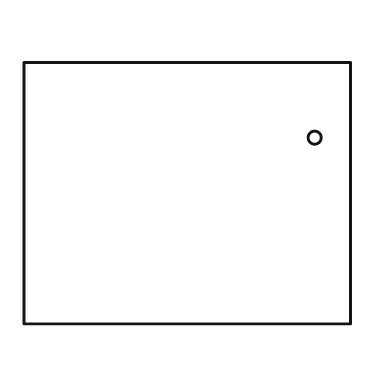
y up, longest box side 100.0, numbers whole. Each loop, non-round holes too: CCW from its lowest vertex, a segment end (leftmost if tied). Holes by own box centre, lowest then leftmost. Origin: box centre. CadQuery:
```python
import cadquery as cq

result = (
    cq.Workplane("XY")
    .moveTo(-50.0, -40.0)
    .lineTo(50.0, -40.0)
    .lineTo(50.0, 40.0)
    .lineTo(-50.0, 40.0)
    .close()
    .moveTo(39.0, 17.0)
    .circle(2.0)
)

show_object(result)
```